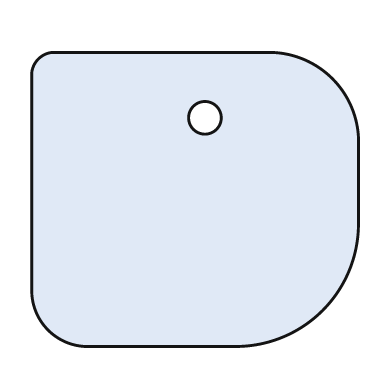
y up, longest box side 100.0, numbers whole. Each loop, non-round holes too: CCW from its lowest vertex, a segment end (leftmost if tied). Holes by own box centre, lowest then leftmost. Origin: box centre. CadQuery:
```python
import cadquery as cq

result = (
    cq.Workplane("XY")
    .moveTo(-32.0, -45.0)
    .lineTo(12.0, -45.0)
    .threePointArc((39.0, -34.0), (50.0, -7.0))
    .lineTo(50.0, 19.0)
    .threePointArc((42.0, 37.0), (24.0, 45.0))
    .lineTo(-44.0, 45.0)
    .threePointArc((-48.0, 43.0), (-50.0, 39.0))
    .lineTo(-50.0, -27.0)
    .threePointArc((-45.0, -40.0), (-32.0, -45.0))
    .close()
    .moveTo(3.0, 25.0)
    .circle(5.0)
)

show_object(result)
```